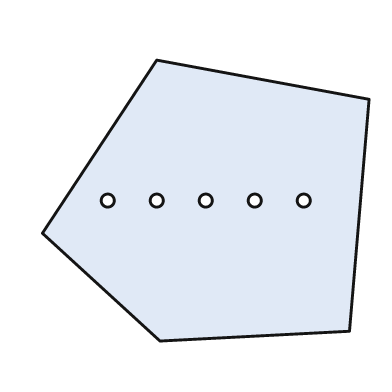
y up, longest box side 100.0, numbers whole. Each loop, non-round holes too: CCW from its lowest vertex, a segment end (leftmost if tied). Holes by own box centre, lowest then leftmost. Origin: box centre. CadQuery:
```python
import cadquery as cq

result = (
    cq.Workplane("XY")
    .moveTo(-14.0, -43.0)
    .lineTo(44.0, -40.0)
    .lineTo(50.0, 31.0)
    .lineTo(-15.0, 43.0)
    .lineTo(-50.0, -10.0)
    .close()
    .moveTo(-30.0, 0.0)
    .circle(2.0)
    .moveTo(-15.0, 0.0)
    .circle(2.0)
    .moveTo(0.0, 0.0)
    .circle(2.0)
    .moveTo(15.0, 0.0)
    .circle(2.0)
    .moveTo(30.0, 0.0)
    .circle(2.0)
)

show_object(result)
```